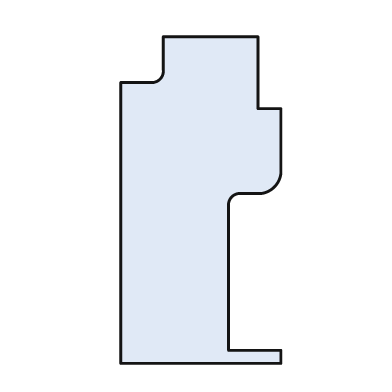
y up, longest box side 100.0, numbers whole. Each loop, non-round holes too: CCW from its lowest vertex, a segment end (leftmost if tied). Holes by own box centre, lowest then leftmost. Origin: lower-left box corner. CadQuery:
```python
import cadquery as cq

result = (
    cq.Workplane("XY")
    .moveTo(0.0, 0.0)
    .lineTo(49.0, 0.0)
    .lineTo(49.0, 4.0)
    .lineTo(33.0, 4.0)
    .lineTo(33.0, 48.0)
    .threePointArc((34.0, 51.0), (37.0, 52.0))
    .lineTo(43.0, 52.0)
    .threePointArc((47.0, 54.0), (49.0, 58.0))
    .lineTo(49.0, 78.0)
    .lineTo(42.0, 78.0)
    .lineTo(42.0, 100.0)
    .lineTo(13.0, 100.0)
    .lineTo(13.0, 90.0)
    .threePointArc((12.0, 87.0), (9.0, 86.0))
    .lineTo(0.0, 86.0)
    .close()
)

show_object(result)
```